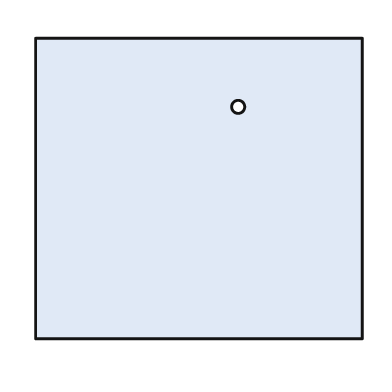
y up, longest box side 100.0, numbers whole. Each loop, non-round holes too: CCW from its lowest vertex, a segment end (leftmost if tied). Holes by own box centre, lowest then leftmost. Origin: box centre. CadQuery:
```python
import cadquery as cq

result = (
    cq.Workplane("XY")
    .moveTo(-50.0, -46.0)
    .lineTo(50.0, -46.0)
    .lineTo(50.0, 46.0)
    .lineTo(-50.0, 46.0)
    .close()
    .moveTo(12.0, 25.0)
    .circle(2.0)
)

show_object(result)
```